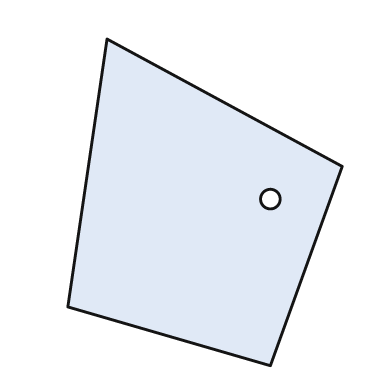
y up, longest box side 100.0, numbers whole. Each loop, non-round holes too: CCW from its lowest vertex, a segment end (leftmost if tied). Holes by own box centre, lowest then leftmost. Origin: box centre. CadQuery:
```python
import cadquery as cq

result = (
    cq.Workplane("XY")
    .moveTo(20.0, -50.0)
    .lineTo(42.0, 11.0)
    .lineTo(-30.0, 50.0)
    .lineTo(-42.0, -32.0)
    .close()
    .moveTo(20.0, 1.0)
    .circle(3.0)
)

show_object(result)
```